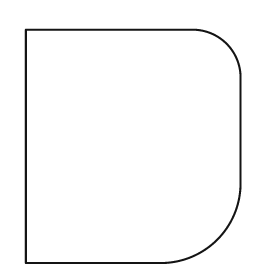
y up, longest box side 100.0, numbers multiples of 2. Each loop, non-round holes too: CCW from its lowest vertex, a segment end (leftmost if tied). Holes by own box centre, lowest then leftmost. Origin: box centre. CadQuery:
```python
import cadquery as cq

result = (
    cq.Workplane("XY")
    .moveTo(-46.0, -50.0)
    .lineTo(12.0, -50.0)
    .threePointArc((36.0, -40.0), (46.0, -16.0))
    .lineTo(46.0, 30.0)
    .threePointArc((40.0, 44.0), (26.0, 50.0))
    .lineTo(-46.0, 50.0)
    .close()
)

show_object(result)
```